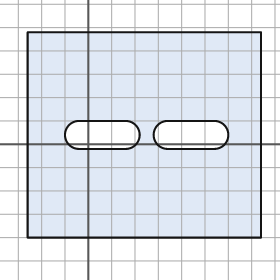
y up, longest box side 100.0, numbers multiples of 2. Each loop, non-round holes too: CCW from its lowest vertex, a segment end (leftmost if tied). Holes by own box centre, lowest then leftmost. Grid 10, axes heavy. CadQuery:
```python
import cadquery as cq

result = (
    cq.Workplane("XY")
    .moveTo(-26.0, -40.0)
    .lineTo(74.0, -40.0)
    .lineTo(74.0, 48.0)
    .lineTo(-26.0, 48.0)
    .close()
    .moveTo(-4.0, -2.0)
    .lineTo(16.0, -2.0)
    .threePointArc((22.0, 4.0), (16.0, 10.0))
    .lineTo(-4.0, 10.0)
    .threePointArc((-10.0, 4.0), (-4.0, -2.0))
    .close()
    .moveTo(34.0, -2.0)
    .lineTo(54.0, -2.0)
    .threePointArc((60.0, 4.0), (54.0, 10.0))
    .lineTo(34.0, 10.0)
    .threePointArc((28.0, 4.0), (34.0, -2.0))
    .close()
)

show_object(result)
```